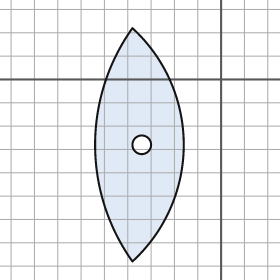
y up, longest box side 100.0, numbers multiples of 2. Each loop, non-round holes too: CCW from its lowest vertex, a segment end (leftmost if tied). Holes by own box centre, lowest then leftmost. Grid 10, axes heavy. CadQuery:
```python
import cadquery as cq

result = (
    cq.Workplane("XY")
    .moveTo(-38.0, -78.0)
    .threePointArc((-16.0, -28.0), (-38.0, 22.0))
    .threePointArc((-54.0, -28.0), (-38.0, -78.0))
    .close()
    .moveTo(-34.0, -28.0)
    .circle(4.0)
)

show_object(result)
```